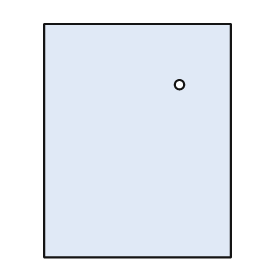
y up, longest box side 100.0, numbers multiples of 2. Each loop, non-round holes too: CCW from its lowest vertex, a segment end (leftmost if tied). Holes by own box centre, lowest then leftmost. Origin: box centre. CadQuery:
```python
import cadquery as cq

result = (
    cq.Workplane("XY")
    .moveTo(-40.0, -50.0)
    .lineTo(40.0, -50.0)
    .lineTo(40.0, 50.0)
    .lineTo(-40.0, 50.0)
    .close()
    .moveTo(18.0, 24.0)
    .circle(2.0)
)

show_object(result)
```